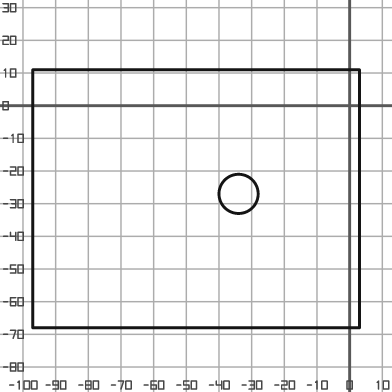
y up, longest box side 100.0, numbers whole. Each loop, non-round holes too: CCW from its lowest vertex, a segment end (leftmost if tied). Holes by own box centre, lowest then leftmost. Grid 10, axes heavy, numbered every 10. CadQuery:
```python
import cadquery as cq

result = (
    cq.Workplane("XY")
    .moveTo(-97.0, -68.0)
    .lineTo(3.0, -68.0)
    .lineTo(3.0, 11.0)
    .lineTo(-97.0, 11.0)
    .close()
    .moveTo(-34.0, -27.0)
    .circle(6.0)
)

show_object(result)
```